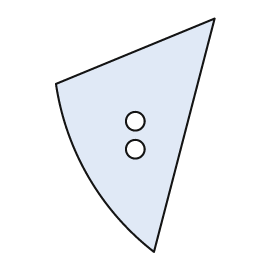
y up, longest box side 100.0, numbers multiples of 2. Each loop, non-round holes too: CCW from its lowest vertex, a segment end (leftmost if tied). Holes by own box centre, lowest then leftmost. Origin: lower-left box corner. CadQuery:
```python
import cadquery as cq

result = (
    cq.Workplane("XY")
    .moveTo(42.0, 0.0)
    .lineTo(68.0, 100.0)
    .lineTo(0.0, 72.0)
    .threePointArc((14.0, 32.0), (42.0, 0.0))
    .close()
    .moveTo(34.0, 44.0)
    .circle(4.0)
    .moveTo(34.0, 56.0)
    .circle(4.0)
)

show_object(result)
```